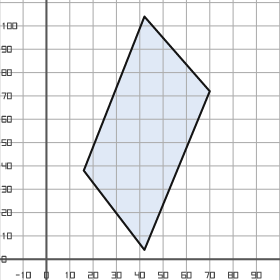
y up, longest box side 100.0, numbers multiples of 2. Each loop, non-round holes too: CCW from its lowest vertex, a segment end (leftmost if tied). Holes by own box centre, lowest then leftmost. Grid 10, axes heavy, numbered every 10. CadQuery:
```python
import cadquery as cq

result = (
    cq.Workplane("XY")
    .moveTo(42.0, 4.0)
    .lineTo(70.0, 72.0)
    .lineTo(42.0, 104.0)
    .lineTo(16.0, 38.0)
    .close()
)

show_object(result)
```